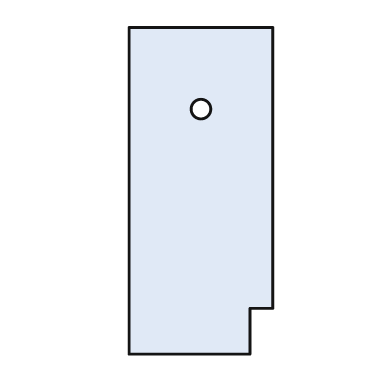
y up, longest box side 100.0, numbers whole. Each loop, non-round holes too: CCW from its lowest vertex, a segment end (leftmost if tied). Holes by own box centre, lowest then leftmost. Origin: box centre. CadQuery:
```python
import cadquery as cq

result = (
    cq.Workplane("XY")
    .moveTo(-22.0, -50.0)
    .lineTo(15.0, -50.0)
    .lineTo(15.0, -36.0)
    .lineTo(22.0, -36.0)
    .lineTo(22.0, 50.0)
    .lineTo(-22.0, 50.0)
    .close()
    .moveTo(0.0, 25.0)
    .circle(3.0)
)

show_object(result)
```